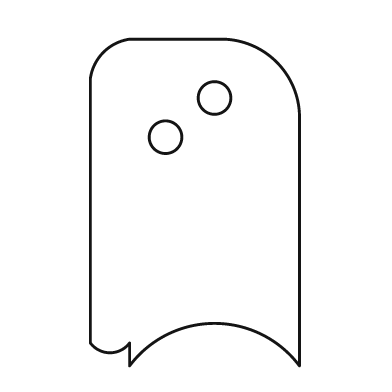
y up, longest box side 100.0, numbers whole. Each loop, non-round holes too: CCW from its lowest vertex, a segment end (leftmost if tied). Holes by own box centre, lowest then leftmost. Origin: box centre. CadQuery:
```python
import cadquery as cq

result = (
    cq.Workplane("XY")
    .moveTo(-20.0, -50.0)
    .threePointArc((6.0, -37.0), (32.0, -50.0))
    .lineTo(32.0, 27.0)
    .threePointArc((25.0, 43.0), (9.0, 50.0))
    .lineTo(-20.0, 50.0)
    .threePointArc((-28.0, 46.0), (-32.0, 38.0))
    .lineTo(-32.0, -43.0)
    .threePointArc((-26.0, -46.0), (-20.0, -43.0))
    .close()
    .moveTo(-9.0, 20.0)
    .circle(5.0)
    .moveTo(6.0, 32.0)
    .circle(5.0)
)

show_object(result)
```